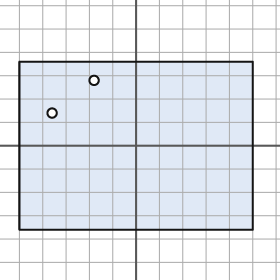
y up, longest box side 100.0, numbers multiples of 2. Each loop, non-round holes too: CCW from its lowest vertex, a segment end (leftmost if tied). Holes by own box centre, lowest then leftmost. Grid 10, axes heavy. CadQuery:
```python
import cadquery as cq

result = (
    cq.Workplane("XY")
    .moveTo(-50.0, -36.0)
    .lineTo(50.0, -36.0)
    .lineTo(50.0, 36.0)
    .lineTo(-50.0, 36.0)
    .close()
    .moveTo(-36.0, 14.0)
    .circle(2.0)
    .moveTo(-18.0, 28.0)
    .circle(2.0)
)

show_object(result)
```